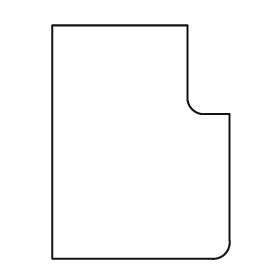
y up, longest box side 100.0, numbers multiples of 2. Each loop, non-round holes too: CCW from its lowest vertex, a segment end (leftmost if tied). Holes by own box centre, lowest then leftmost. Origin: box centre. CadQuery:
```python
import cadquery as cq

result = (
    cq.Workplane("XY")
    .moveTo(-38.0, -50.0)
    .lineTo(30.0, -50.0)
    .threePointArc((36.0, -48.0), (38.0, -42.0))
    .lineTo(38.0, 12.0)
    .lineTo(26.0, 12.0)
    .threePointArc((22.0, 14.0), (20.0, 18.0))
    .lineTo(20.0, 50.0)
    .lineTo(-38.0, 50.0)
    .close()
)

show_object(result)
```